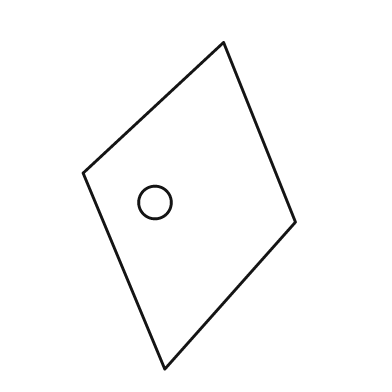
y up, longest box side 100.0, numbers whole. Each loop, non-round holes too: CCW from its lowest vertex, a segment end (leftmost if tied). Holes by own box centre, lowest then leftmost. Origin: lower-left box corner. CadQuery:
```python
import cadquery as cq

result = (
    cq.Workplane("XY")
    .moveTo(25.0, 0.0)
    .lineTo(65.0, 45.0)
    .lineTo(43.0, 100.0)
    .lineTo(0.0, 60.0)
    .close()
    .moveTo(22.0, 51.0)
    .circle(5.0)
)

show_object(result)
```